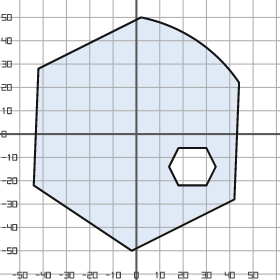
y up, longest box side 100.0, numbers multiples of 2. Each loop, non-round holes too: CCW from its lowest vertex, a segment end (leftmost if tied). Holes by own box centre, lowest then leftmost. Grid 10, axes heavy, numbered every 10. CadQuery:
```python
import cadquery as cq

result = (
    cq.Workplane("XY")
    .moveTo(-2.0, -50.0)
    .lineTo(42.0, -28.0)
    .lineTo(44.0, 22.0)
    .threePointArc((26.0, 40.0), (2.0, 50.0))
    .lineTo(-42.0, 28.0)
    .lineTo(-44.0, -22.0)
    .close()
    .moveTo(18.0, -22.0)
    .lineTo(30.0, -22.0)
    .lineTo(34.0, -14.0)
    .lineTo(30.0, -6.0)
    .lineTo(18.0, -6.0)
    .lineTo(14.0, -14.0)
    .close()
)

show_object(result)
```